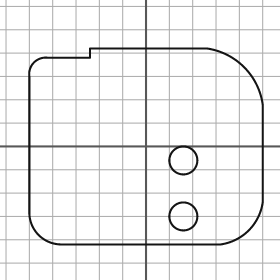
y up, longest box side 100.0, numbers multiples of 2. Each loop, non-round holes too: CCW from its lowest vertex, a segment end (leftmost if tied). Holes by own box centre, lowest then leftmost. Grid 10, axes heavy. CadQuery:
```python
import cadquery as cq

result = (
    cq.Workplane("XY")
    .moveTo(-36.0, -42.0)
    .lineTo(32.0, -42.0)
    .threePointArc((44.0, -36.0), (50.0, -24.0))
    .lineTo(50.0, 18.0)
    .threePointArc((42.0, 34.0), (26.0, 42.0))
    .lineTo(-24.0, 42.0)
    .lineTo(-24.0, 38.0)
    .lineTo(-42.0, 38.0)
    .threePointArc((-48.0, 36.0), (-50.0, 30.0))
    .lineTo(-50.0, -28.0)
    .threePointArc((-46.0, -38.0), (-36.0, -42.0))
    .close()
    .moveTo(16.0, -30.0)
    .circle(6.0)
    .moveTo(16.0, -6.0)
    .circle(6.0)
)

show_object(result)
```